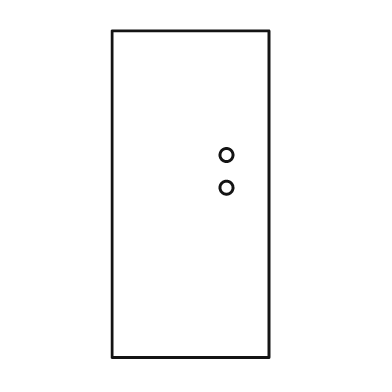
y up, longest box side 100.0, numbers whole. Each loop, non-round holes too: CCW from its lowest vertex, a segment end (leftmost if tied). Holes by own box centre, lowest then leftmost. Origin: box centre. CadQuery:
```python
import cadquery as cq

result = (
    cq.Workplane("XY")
    .moveTo(-24.0, -50.0)
    .lineTo(24.0, -50.0)
    .lineTo(24.0, 50.0)
    .lineTo(-24.0, 50.0)
    .close()
    .moveTo(11.0, 2.0)
    .circle(2.0)
    .moveTo(11.0, 12.0)
    .circle(2.0)
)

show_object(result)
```